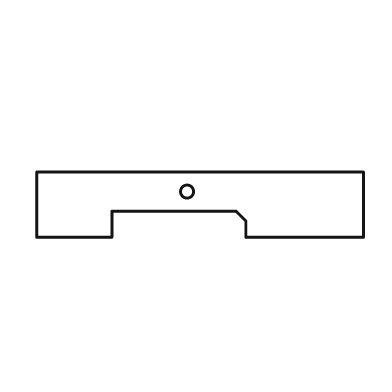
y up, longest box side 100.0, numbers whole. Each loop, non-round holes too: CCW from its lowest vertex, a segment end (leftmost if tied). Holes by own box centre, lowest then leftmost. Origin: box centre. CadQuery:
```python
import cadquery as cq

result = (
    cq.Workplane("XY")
    .moveTo(-50.0, -10.0)
    .lineTo(-27.0, -10.0)
    .lineTo(-27.0, -2.0)
    .lineTo(11.0, -2.0)
    .lineTo(14.0, -5.0)
    .lineTo(14.0, -10.0)
    .lineTo(50.0, -10.0)
    .lineTo(50.0, 10.0)
    .lineTo(-50.0, 10.0)
    .close()
    .moveTo(-4.0, 4.0)
    .circle(2.0)
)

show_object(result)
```